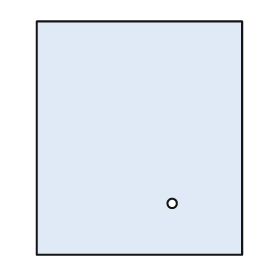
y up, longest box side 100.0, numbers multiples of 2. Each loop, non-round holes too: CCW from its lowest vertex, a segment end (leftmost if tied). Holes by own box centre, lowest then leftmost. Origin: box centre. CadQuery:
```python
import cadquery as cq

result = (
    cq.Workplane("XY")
    .moveTo(-44.0, -50.0)
    .lineTo(44.0, -50.0)
    .lineTo(44.0, 50.0)
    .lineTo(-44.0, 50.0)
    .close()
    .moveTo(14.0, -28.0)
    .circle(2.0)
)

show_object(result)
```